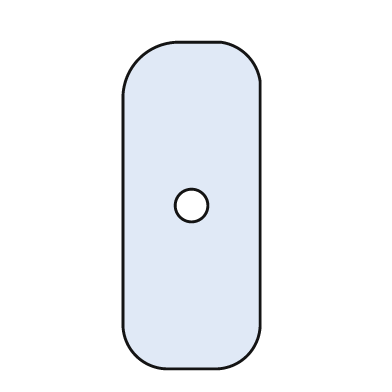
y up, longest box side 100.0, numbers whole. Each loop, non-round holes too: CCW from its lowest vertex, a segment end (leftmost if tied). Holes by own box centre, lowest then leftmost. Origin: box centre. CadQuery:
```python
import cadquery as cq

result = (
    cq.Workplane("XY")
    .moveTo(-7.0, -50.0)
    .lineTo(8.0, -50.0)
    .threePointArc((17.0, -46.0), (21.0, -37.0))
    .lineTo(21.0, 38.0)
    .threePointArc((17.0, 46.0), (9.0, 50.0))
    .lineTo(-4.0, 50.0)
    .threePointArc((-16.0, 45.0), (-21.0, 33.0))
    .lineTo(-21.0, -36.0)
    .threePointArc((-17.0, -46.0), (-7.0, -50.0))
    .close()
    .moveTo(0.0, 0.0)
    .circle(5.0)
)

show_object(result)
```